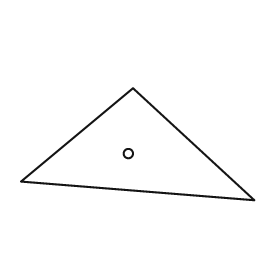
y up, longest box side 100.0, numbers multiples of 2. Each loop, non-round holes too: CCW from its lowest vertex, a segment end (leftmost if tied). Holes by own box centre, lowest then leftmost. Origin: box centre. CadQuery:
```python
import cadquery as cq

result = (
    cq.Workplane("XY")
    .moveTo(50.0, -24.0)
    .lineTo(-2.0, 24.0)
    .lineTo(-50.0, -16.0)
    .close()
    .moveTo(-4.0, -4.0)
    .circle(2.0)
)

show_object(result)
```